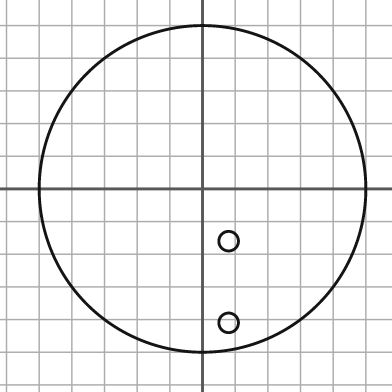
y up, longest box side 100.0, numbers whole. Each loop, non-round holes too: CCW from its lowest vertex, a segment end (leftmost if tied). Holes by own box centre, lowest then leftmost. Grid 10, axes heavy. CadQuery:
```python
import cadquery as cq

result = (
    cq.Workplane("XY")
    .moveTo(0.0, 0.0)
    .circle(50.0)
    .moveTo(8.0, -41.0)
    .circle(3.0)
    .moveTo(8.0, -16.0)
    .circle(3.0)
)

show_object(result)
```